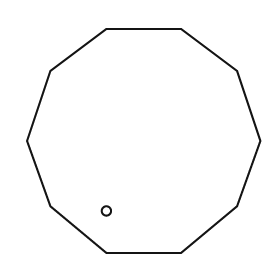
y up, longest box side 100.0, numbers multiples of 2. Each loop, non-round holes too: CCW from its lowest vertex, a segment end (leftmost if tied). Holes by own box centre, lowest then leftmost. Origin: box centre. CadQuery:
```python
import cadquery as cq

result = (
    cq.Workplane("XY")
    .moveTo(-16.0, -48.0)
    .lineTo(16.0, -48.0)
    .lineTo(40.0, -28.0)
    .lineTo(50.0, 0.0)
    .lineTo(40.0, 30.0)
    .lineTo(16.0, 48.0)
    .lineTo(-16.0, 48.0)
    .lineTo(-40.0, 30.0)
    .lineTo(-50.0, 0.0)
    .lineTo(-40.0, -28.0)
    .close()
    .moveTo(-16.0, -30.0)
    .circle(2.0)
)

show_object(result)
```